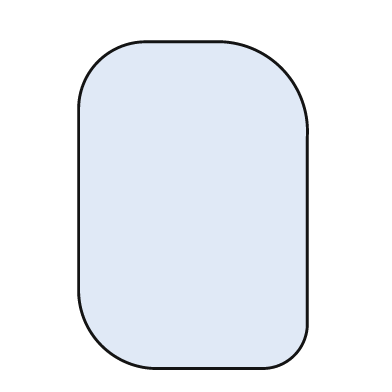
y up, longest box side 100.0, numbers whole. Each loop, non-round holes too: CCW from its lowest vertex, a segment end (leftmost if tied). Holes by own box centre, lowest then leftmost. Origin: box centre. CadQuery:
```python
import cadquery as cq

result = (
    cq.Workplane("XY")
    .moveTo(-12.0, -50.0)
    .lineTo(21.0, -50.0)
    .threePointArc((31.0, -46.0), (35.0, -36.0))
    .lineTo(35.0, 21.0)
    .threePointArc((27.0, 42.0), (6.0, 50.0))
    .lineTo(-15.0, 50.0)
    .threePointArc((-29.0, 44.0), (-35.0, 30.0))
    .lineTo(-35.0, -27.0)
    .threePointArc((-28.0, -43.0), (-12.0, -50.0))
    .close()
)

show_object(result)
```